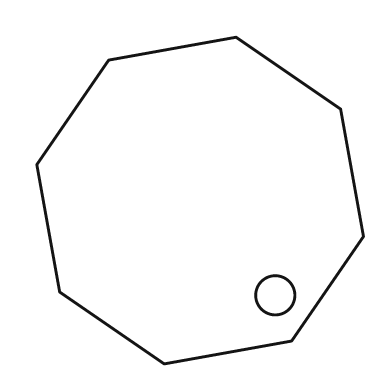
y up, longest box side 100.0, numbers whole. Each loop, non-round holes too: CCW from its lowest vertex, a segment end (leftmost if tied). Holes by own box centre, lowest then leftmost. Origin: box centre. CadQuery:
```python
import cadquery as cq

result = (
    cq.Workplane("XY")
    .moveTo(-11.0, -50.0)
    .lineTo(28.0, -43.0)
    .lineTo(50.0, -11.0)
    .lineTo(43.0, 28.0)
    .lineTo(11.0, 50.0)
    .lineTo(-28.0, 43.0)
    .lineTo(-50.0, 11.0)
    .lineTo(-43.0, -28.0)
    .close()
    .moveTo(23.0, -29.0)
    .circle(6.0)
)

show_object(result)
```